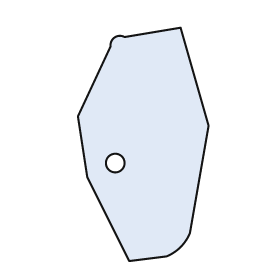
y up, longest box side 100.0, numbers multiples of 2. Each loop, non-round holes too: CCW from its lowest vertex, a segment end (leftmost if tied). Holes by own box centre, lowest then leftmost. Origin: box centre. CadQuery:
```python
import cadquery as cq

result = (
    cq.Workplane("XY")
    .moveTo(-6.0, -50.0)
    .lineTo(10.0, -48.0)
    .threePointArc((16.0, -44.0), (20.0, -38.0))
    .lineTo(28.0, 8.0)
    .lineTo(16.0, 50.0)
    .lineTo(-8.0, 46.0)
    .threePointArc((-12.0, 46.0), (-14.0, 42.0))
    .lineTo(-28.0, 12.0)
    .lineTo(-24.0, -14.0)
    .close()
    .moveTo(-12.0, -8.0)
    .circle(4.0)
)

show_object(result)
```